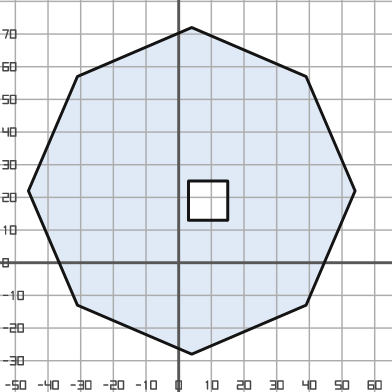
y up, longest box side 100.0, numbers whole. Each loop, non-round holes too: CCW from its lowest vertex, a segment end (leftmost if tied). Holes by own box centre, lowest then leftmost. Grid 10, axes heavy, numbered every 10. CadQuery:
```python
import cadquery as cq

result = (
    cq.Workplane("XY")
    .moveTo(4.0, -28.0)
    .lineTo(39.0, -13.0)
    .lineTo(54.0, 22.0)
    .lineTo(39.0, 57.0)
    .lineTo(4.0, 72.0)
    .lineTo(-31.0, 57.0)
    .lineTo(-46.0, 22.0)
    .lineTo(-31.0, -13.0)
    .close()
    .moveTo(3.0, 13.0)
    .lineTo(15.0, 13.0)
    .lineTo(15.0, 25.0)
    .lineTo(3.0, 25.0)
    .close()
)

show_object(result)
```